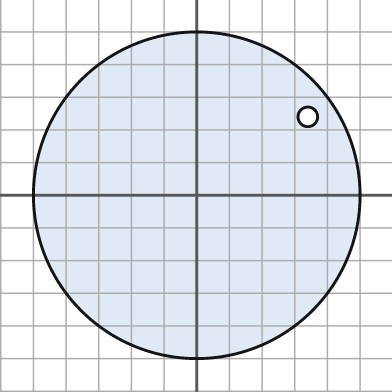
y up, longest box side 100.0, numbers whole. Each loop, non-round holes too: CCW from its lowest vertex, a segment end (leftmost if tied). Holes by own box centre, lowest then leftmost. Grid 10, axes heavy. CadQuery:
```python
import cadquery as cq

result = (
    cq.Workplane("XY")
    .moveTo(0.0, 0.0)
    .circle(50.0)
    .moveTo(34.0, 24.0)
    .circle(3.0)
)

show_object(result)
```